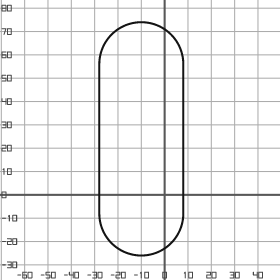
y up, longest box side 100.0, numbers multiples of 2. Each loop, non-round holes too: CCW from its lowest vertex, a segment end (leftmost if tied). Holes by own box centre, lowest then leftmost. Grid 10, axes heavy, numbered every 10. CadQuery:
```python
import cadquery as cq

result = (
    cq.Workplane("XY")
    .moveTo(-28.0, -8.0)
    .threePointArc((-10.0, -26.0), (8.0, -8.0))
    .lineTo(8.0, 56.0)
    .threePointArc((-10.0, 74.0), (-28.0, 56.0))
    .close()
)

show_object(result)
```